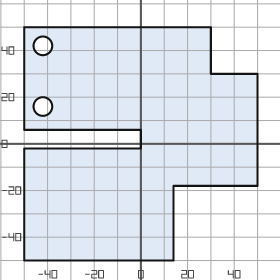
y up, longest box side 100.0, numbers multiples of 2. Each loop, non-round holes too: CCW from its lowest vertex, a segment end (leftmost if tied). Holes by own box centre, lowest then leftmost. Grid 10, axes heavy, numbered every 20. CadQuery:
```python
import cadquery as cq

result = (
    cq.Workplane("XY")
    .moveTo(-50.0, -50.0)
    .lineTo(14.0, -50.0)
    .lineTo(14.0, -18.0)
    .lineTo(50.0, -18.0)
    .lineTo(50.0, 30.0)
    .lineTo(30.0, 30.0)
    .lineTo(30.0, 50.0)
    .lineTo(-50.0, 50.0)
    .lineTo(-50.0, 6.0)
    .lineTo(0.0, 6.0)
    .lineTo(0.0, -2.0)
    .lineTo(-50.0, -2.0)
    .close()
    .moveTo(-42.0, 16.0)
    .circle(4.0)
    .moveTo(-42.0, 42.0)
    .circle(4.0)
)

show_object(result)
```